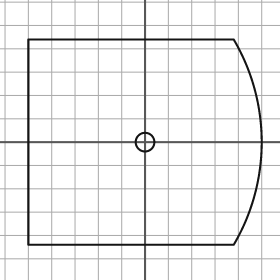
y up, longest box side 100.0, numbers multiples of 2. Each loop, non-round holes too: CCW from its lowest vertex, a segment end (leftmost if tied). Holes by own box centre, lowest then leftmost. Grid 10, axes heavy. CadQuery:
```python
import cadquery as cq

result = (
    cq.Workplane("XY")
    .moveTo(-50.0, -44.0)
    .lineTo(38.0, -44.0)
    .threePointArc((50.0, 0.0), (38.0, 44.0))
    .lineTo(-50.0, 44.0)
    .close()
    .moveTo(0.0, 0.0)
    .circle(4.0)
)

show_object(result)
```